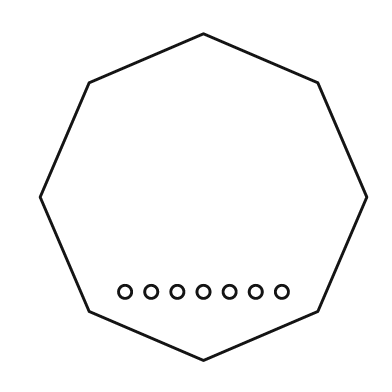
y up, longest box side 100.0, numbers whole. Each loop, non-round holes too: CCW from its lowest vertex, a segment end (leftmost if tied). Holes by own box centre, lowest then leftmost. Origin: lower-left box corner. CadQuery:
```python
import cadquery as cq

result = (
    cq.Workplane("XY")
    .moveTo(50.0, 0.0)
    .lineTo(85.0, 15.0)
    .lineTo(100.0, 50.0)
    .lineTo(85.0, 85.0)
    .lineTo(50.0, 100.0)
    .lineTo(15.0, 85.0)
    .lineTo(0.0, 50.0)
    .lineTo(15.0, 15.0)
    .close()
    .moveTo(26.0, 21.0)
    .circle(2.0)
    .moveTo(34.0, 21.0)
    .circle(2.0)
    .moveTo(42.0, 21.0)
    .circle(2.0)
    .moveTo(50.0, 21.0)
    .circle(2.0)
    .moveTo(58.0, 21.0)
    .circle(2.0)
    .moveTo(66.0, 21.0)
    .circle(2.0)
    .moveTo(74.0, 21.0)
    .circle(2.0)
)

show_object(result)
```